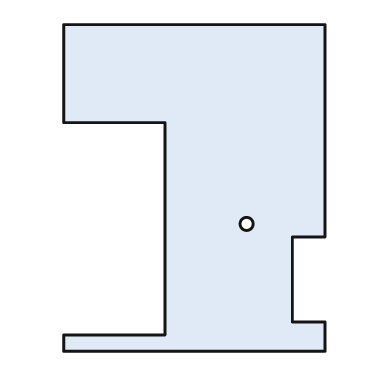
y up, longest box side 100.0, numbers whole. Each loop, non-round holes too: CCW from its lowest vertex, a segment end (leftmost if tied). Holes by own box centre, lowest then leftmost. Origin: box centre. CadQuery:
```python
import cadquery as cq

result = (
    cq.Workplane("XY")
    .moveTo(-40.0, -50.0)
    .lineTo(40.0, -50.0)
    .lineTo(40.0, -41.0)
    .lineTo(30.0, -41.0)
    .lineTo(30.0, -15.0)
    .lineTo(40.0, -15.0)
    .lineTo(40.0, 50.0)
    .lineTo(-40.0, 50.0)
    .lineTo(-40.0, 20.0)
    .lineTo(-9.0, 20.0)
    .lineTo(-9.0, -45.0)
    .lineTo(-40.0, -45.0)
    .close()
    .moveTo(16.0, -11.0)
    .circle(2.0)
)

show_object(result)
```